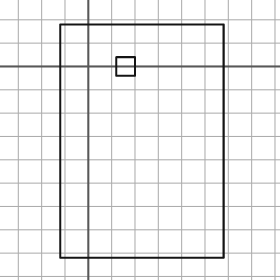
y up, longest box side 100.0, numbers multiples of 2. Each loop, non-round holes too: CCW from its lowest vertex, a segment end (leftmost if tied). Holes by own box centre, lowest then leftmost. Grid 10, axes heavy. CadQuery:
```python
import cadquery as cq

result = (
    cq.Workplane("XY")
    .moveTo(-12.0, -82.0)
    .lineTo(58.0, -82.0)
    .lineTo(58.0, 18.0)
    .lineTo(-12.0, 18.0)
    .close()
    .moveTo(12.0, -4.0)
    .lineTo(20.0, -4.0)
    .lineTo(20.0, 4.0)
    .lineTo(12.0, 4.0)
    .close()
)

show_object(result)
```